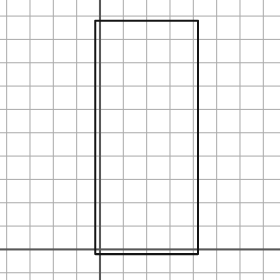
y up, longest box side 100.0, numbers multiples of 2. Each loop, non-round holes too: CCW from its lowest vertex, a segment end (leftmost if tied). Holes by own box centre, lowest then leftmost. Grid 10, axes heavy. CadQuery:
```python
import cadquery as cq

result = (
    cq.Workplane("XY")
    .moveTo(-2.0, -2.0)
    .lineTo(42.0, -2.0)
    .lineTo(42.0, 98.0)
    .lineTo(-2.0, 98.0)
    .close()
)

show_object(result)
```